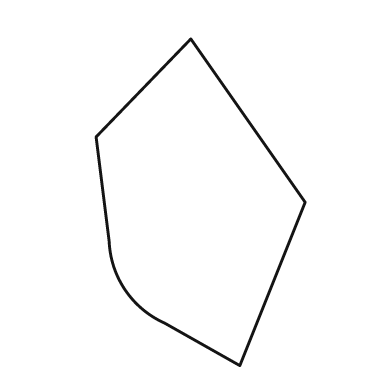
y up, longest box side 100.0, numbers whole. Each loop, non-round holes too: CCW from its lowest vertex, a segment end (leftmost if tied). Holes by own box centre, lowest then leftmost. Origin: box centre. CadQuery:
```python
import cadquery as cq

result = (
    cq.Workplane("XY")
    .moveTo(12.0, -50.0)
    .lineTo(32.0, 0.0)
    .lineTo(-3.0, 50.0)
    .lineTo(-32.0, 20.0)
    .lineTo(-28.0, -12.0)
    .threePointArc((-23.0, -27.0), (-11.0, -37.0))
    .close()
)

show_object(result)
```